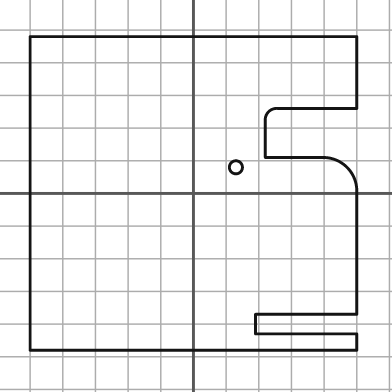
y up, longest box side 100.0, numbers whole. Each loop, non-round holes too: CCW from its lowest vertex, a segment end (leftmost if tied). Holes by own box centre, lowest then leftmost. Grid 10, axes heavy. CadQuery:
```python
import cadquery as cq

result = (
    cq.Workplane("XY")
    .moveTo(-50.0, -48.0)
    .lineTo(50.0, -48.0)
    .lineTo(50.0, -43.0)
    .lineTo(19.0, -43.0)
    .lineTo(19.0, -37.0)
    .lineTo(50.0, -37.0)
    .lineTo(50.0, 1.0)
    .threePointArc((47.0, 8.0), (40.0, 11.0))
    .lineTo(22.0, 11.0)
    .lineTo(22.0, 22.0)
    .threePointArc((23.0, 25.0), (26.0, 26.0))
    .lineTo(50.0, 26.0)
    .lineTo(50.0, 48.0)
    .lineTo(-50.0, 48.0)
    .close()
    .moveTo(13.0, 8.0)
    .circle(2.0)
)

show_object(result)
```